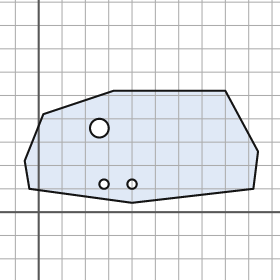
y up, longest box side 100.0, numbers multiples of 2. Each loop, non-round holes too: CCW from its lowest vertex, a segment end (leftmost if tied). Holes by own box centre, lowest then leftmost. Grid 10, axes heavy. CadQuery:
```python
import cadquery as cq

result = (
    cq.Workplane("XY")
    .moveTo(40.0, 4.0)
    .lineTo(92.0, 10.0)
    .lineTo(94.0, 26.0)
    .lineTo(80.0, 52.0)
    .lineTo(32.0, 52.0)
    .lineTo(2.0, 42.0)
    .lineTo(-6.0, 22.0)
    .lineTo(-4.0, 10.0)
    .close()
    .moveTo(28.0, 12.0)
    .circle(2.0)
    .moveTo(40.0, 12.0)
    .circle(2.0)
    .moveTo(26.0, 36.0)
    .circle(4.0)
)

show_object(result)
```